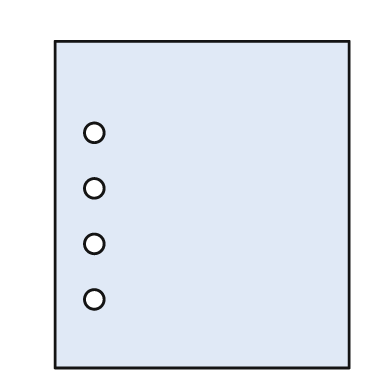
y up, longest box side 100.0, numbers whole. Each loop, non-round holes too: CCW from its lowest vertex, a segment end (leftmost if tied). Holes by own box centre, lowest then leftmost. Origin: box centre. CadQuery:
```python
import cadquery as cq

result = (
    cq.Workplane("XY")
    .moveTo(-45.0, -50.0)
    .lineTo(45.0, -50.0)
    .lineTo(45.0, 50.0)
    .lineTo(-45.0, 50.0)
    .close()
    .moveTo(-33.0, -29.0)
    .circle(3.0)
    .moveTo(-33.0, -12.0)
    .circle(3.0)
    .moveTo(-33.0, 5.0)
    .circle(3.0)
    .moveTo(-33.0, 22.0)
    .circle(3.0)
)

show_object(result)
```